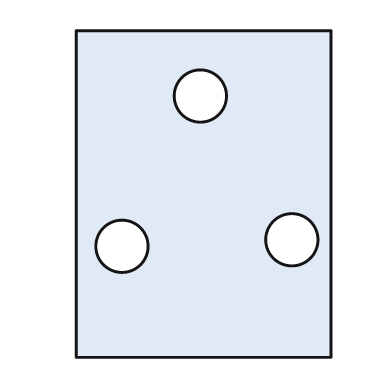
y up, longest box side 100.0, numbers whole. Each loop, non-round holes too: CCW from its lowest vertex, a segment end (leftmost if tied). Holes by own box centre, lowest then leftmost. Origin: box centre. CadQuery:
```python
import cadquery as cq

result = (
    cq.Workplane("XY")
    .moveTo(-39.0, -50.0)
    .lineTo(39.0, -50.0)
    .lineTo(39.0, 50.0)
    .lineTo(-39.0, 50.0)
    .close()
    .moveTo(-25.0, -16.0)
    .circle(8.0)
    .moveTo(27.0, -14.0)
    .circle(8.0)
    .moveTo(-1.0, 30.0)
    .circle(8.0)
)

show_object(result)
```